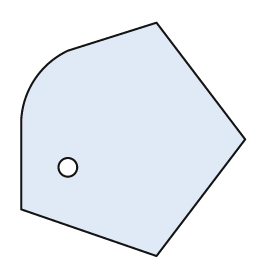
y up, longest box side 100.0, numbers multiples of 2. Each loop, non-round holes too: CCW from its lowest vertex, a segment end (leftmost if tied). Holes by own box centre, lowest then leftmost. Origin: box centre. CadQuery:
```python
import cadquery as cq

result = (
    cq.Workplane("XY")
    .moveTo(10.0, -50.0)
    .lineTo(48.0, 0.0)
    .lineTo(10.0, 50.0)
    .lineTo(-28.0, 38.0)
    .threePointArc((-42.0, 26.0), (-48.0, 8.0))
    .lineTo(-48.0, -30.0)
    .close()
    .moveTo(-28.0, -12.0)
    .circle(4.0)
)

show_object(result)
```